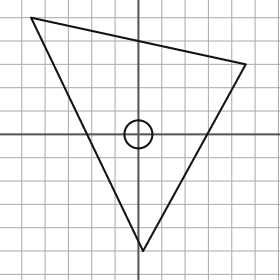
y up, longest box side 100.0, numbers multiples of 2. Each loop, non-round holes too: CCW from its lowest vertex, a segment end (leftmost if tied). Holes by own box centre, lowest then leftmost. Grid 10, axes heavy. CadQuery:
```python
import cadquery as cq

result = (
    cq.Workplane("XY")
    .moveTo(2.0, -50.0)
    .lineTo(46.0, 30.0)
    .lineTo(-46.0, 50.0)
    .close()
    .moveTo(0.0, 0.0)
    .circle(6.0)
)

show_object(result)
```